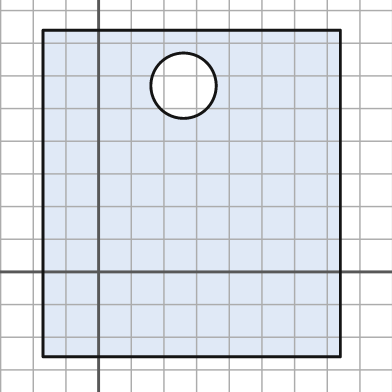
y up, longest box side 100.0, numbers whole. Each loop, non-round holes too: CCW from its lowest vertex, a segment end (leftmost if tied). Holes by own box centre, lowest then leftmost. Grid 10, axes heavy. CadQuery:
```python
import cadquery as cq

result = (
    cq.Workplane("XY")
    .moveTo(-17.0, -26.0)
    .lineTo(74.0, -26.0)
    .lineTo(74.0, 74.0)
    .lineTo(-17.0, 74.0)
    .close()
    .moveTo(26.0, 57.0)
    .circle(10.0)
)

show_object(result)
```